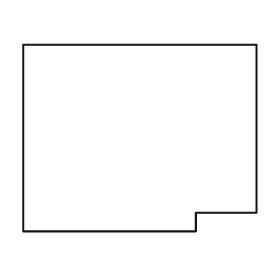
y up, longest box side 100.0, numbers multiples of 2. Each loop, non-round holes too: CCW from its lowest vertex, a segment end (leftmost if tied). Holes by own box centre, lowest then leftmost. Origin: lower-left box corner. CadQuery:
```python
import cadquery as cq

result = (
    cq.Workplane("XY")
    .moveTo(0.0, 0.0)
    .lineTo(74.0, 0.0)
    .lineTo(74.0, 8.0)
    .lineTo(100.0, 8.0)
    .lineTo(100.0, 80.0)
    .lineTo(0.0, 80.0)
    .close()
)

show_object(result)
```